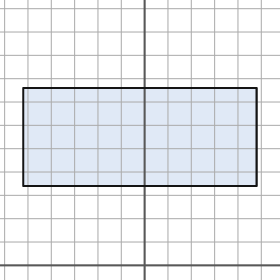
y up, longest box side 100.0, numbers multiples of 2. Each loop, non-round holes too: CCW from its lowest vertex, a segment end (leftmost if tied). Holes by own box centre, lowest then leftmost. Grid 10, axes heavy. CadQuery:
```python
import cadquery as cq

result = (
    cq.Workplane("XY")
    .moveTo(-52.0, 34.0)
    .lineTo(48.0, 34.0)
    .lineTo(48.0, 76.0)
    .lineTo(-52.0, 76.0)
    .close()
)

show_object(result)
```